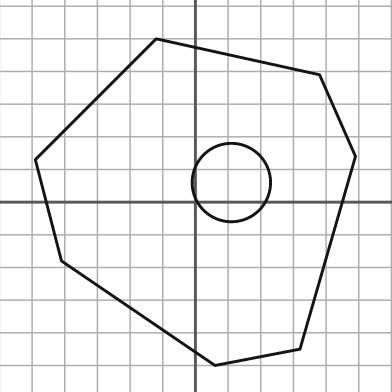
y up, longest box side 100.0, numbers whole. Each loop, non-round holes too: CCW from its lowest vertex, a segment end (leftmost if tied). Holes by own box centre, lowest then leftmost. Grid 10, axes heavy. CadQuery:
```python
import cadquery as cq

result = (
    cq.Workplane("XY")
    .moveTo(6.0, -50.0)
    .lineTo(32.0, -45.0)
    .lineTo(49.0, 14.0)
    .lineTo(38.0, 39.0)
    .lineTo(-12.0, 50.0)
    .lineTo(-49.0, 13.0)
    .lineTo(-41.0, -18.0)
    .close()
    .moveTo(11.0, 6.0)
    .circle(12.0)
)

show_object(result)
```